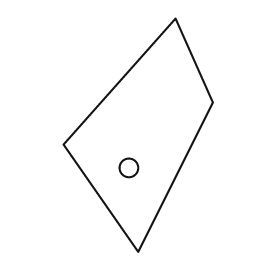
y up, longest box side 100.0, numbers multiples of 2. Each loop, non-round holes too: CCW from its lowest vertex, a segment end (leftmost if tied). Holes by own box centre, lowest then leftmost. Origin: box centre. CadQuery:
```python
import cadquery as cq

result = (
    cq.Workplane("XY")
    .moveTo(0.0, -50.0)
    .lineTo(32.0, 14.0)
    .lineTo(16.0, 50.0)
    .lineTo(-32.0, -4.0)
    .close()
    .moveTo(-4.0, -14.0)
    .circle(4.0)
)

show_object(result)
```